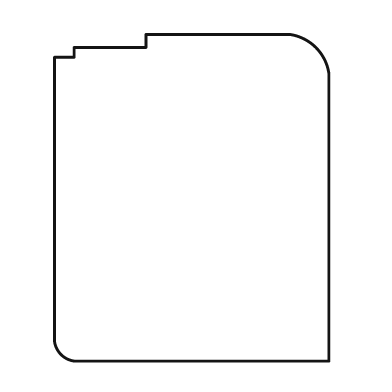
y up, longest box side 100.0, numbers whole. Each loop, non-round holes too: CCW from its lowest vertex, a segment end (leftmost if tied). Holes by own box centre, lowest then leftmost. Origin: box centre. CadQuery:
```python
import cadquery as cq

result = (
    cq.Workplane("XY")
    .moveTo(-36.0, -50.0)
    .lineTo(42.0, -50.0)
    .lineTo(42.0, 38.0)
    .threePointArc((38.0, 46.0), (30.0, 50.0))
    .lineTo(-14.0, 50.0)
    .lineTo(-14.0, 46.0)
    .lineTo(-36.0, 46.0)
    .lineTo(-36.0, 43.0)
    .lineTo(-42.0, 43.0)
    .lineTo(-42.0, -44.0)
    .threePointArc((-40.0, -48.0), (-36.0, -50.0))
    .close()
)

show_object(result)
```